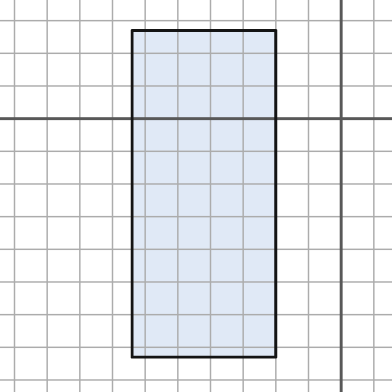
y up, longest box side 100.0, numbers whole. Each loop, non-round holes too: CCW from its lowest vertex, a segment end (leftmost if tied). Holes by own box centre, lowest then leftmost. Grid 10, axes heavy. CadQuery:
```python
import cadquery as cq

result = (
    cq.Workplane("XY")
    .moveTo(-64.0, -73.0)
    .lineTo(-20.0, -73.0)
    .lineTo(-20.0, 27.0)
    .lineTo(-64.0, 27.0)
    .close()
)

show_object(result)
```